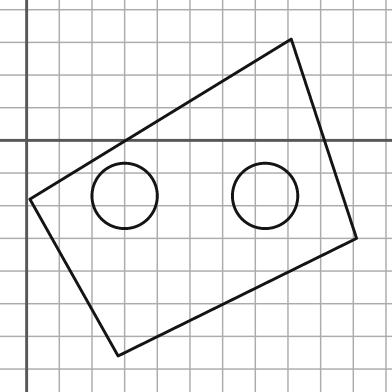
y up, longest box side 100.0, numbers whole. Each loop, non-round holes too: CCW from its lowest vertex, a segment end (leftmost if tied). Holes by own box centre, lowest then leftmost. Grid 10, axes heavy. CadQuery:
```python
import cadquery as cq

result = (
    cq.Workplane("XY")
    .moveTo(28.0, -66.0)
    .lineTo(101.0, -30.0)
    .lineTo(81.0, 31.0)
    .lineTo(1.0, -18.0)
    .close()
    .moveTo(30.0, -17.0)
    .circle(10.0)
    .moveTo(73.0, -17.0)
    .circle(10.0)
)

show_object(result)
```